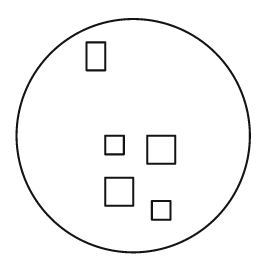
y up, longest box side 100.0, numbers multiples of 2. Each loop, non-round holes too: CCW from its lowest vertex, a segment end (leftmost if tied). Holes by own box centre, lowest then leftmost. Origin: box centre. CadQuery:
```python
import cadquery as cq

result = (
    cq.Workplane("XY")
    .moveTo(0.0, 0.0)
    .circle(50.0)
    .moveTo(8.0, -36.0)
    .lineTo(16.0, -36.0)
    .lineTo(16.0, -28.0)
    .lineTo(8.0, -28.0)
    .close()
    .moveTo(-12.0, -30.0)
    .lineTo(0.0, -30.0)
    .lineTo(0.0, -18.0)
    .lineTo(-12.0, -18.0)
    .close()
    .moveTo(6.0, -12.0)
    .lineTo(18.0, -12.0)
    .lineTo(18.0, 0.0)
    .lineTo(6.0, 0.0)
    .close()
    .moveTo(-12.0, -8.0)
    .lineTo(-4.0, -8.0)
    .lineTo(-4.0, 0.0)
    .lineTo(-12.0, 0.0)
    .close()
    .moveTo(-20.0, 28.0)
    .lineTo(-12.0, 28.0)
    .lineTo(-12.0, 40.0)
    .lineTo(-20.0, 40.0)
    .close()
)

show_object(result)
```